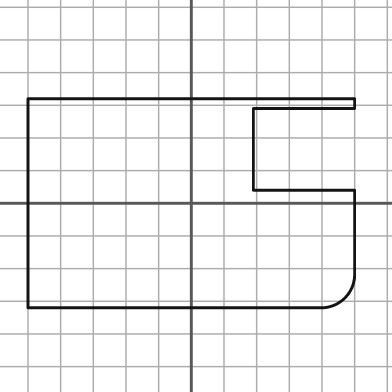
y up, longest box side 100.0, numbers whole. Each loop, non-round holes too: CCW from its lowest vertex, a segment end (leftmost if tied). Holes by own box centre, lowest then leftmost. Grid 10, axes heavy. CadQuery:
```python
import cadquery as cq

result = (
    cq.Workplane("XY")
    .moveTo(-50.0, -32.0)
    .lineTo(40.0, -32.0)
    .threePointArc((47.0, -29.0), (50.0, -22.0))
    .lineTo(50.0, 4.0)
    .lineTo(19.0, 4.0)
    .lineTo(19.0, 29.0)
    .lineTo(50.0, 29.0)
    .lineTo(50.0, 32.0)
    .lineTo(-50.0, 32.0)
    .close()
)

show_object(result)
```